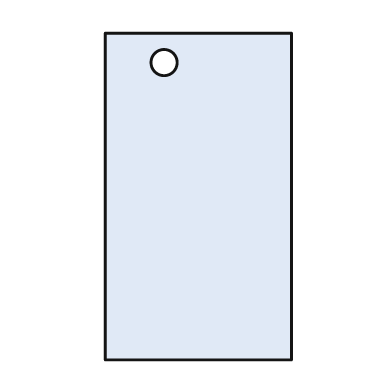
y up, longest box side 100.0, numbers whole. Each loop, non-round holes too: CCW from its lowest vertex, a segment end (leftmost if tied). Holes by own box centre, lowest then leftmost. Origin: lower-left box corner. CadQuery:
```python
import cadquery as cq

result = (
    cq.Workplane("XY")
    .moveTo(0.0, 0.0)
    .lineTo(57.0, 0.0)
    .lineTo(57.0, 100.0)
    .lineTo(0.0, 100.0)
    .close()
    .moveTo(18.0, 91.0)
    .circle(4.0)
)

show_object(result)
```